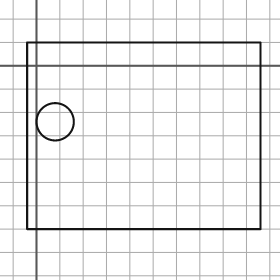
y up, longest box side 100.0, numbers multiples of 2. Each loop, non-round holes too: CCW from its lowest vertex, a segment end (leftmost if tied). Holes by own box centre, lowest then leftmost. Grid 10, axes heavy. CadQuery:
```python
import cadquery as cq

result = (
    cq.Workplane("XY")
    .moveTo(-4.0, -70.0)
    .lineTo(96.0, -70.0)
    .lineTo(96.0, 10.0)
    .lineTo(-4.0, 10.0)
    .close()
    .moveTo(8.0, -24.0)
    .circle(8.0)
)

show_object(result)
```